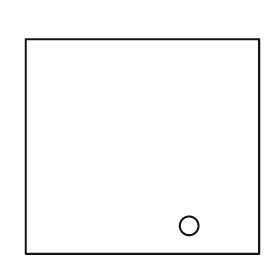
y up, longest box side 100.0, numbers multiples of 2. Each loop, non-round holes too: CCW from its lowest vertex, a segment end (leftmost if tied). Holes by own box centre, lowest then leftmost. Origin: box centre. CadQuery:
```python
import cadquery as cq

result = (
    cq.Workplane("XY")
    .moveTo(-50.0, -46.0)
    .lineTo(50.0, -46.0)
    .lineTo(50.0, 46.0)
    .lineTo(-50.0, 46.0)
    .close()
    .moveTo(20.0, -34.0)
    .circle(4.0)
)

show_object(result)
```